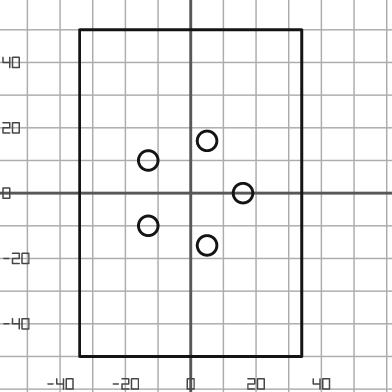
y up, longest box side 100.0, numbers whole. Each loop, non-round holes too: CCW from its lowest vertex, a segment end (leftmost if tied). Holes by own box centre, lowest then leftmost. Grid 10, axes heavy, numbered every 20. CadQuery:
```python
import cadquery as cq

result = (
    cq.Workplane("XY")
    .moveTo(-34.0, -50.0)
    .lineTo(34.0, -50.0)
    .lineTo(34.0, 50.0)
    .lineTo(-34.0, 50.0)
    .close()
    .moveTo(5.0, -16.0)
    .circle(3.0)
    .moveTo(-13.0, -10.0)
    .circle(3.0)
    .moveTo(16.0, 0.0)
    .circle(3.0)
    .moveTo(-13.0, 10.0)
    .circle(3.0)
    .moveTo(5.0, 16.0)
    .circle(3.0)
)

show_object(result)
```